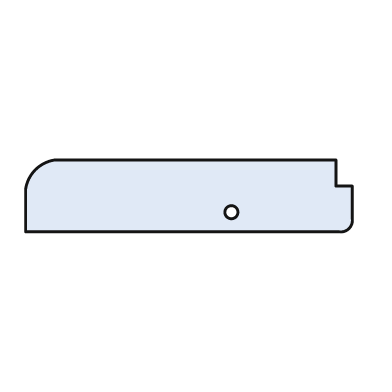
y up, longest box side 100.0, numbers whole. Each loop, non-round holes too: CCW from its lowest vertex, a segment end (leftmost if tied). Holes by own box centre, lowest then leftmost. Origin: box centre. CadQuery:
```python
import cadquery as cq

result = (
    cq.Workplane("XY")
    .moveTo(-50.0, -11.0)
    .lineTo(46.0, -11.0)
    .threePointArc((49.0, -10.0), (50.0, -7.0))
    .lineTo(50.0, 3.0)
    .lineTo(45.0, 3.0)
    .lineTo(45.0, 11.0)
    .lineTo(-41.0, 11.0)
    .threePointArc((-47.0, 8.0), (-50.0, 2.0))
    .close()
    .moveTo(13.0, -5.0)
    .circle(2.0)
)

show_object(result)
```